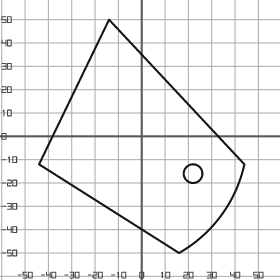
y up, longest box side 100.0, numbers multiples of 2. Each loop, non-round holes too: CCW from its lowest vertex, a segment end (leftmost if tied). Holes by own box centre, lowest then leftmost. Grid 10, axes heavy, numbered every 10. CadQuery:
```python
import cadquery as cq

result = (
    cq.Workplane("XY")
    .moveTo(16.0, -50.0)
    .threePointArc((34.0, -34.0), (44.0, -12.0))
    .lineTo(-14.0, 50.0)
    .lineTo(-44.0, -12.0)
    .close()
    .moveTo(22.0, -16.0)
    .circle(4.0)
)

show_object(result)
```